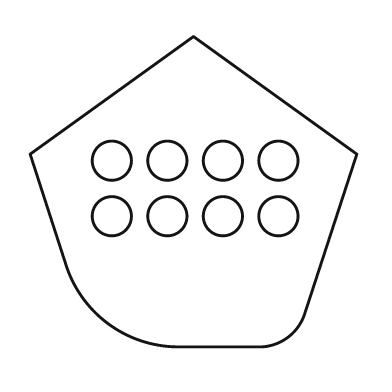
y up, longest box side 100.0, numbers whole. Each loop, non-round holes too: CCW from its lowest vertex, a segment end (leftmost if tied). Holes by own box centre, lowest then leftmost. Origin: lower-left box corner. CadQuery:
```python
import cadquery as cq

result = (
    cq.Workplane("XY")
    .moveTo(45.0, 0.0)
    .lineTo(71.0, 0.0)
    .threePointArc((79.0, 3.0), (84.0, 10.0))
    .lineTo(100.0, 59.0)
    .lineTo(50.0, 95.0)
    .lineTo(0.0, 59.0)
    .lineTo(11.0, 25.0)
    .threePointArc((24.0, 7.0), (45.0, 0.0))
    .close()
    .moveTo(25.0, 40.0)
    .circle(6.0)
    .moveTo(42.0, 40.0)
    .circle(6.0)
    .moveTo(59.0, 40.0)
    .circle(6.0)
    .moveTo(76.0, 40.0)
    .circle(6.0)
    .moveTo(25.0, 57.0)
    .circle(6.0)
    .moveTo(42.0, 57.0)
    .circle(6.0)
    .moveTo(59.0, 57.0)
    .circle(6.0)
    .moveTo(76.0, 57.0)
    .circle(6.0)
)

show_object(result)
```